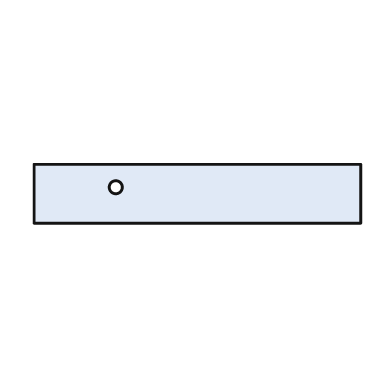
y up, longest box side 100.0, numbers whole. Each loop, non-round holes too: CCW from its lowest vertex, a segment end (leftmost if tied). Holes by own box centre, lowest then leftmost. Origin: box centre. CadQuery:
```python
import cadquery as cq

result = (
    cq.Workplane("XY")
    .moveTo(-50.0, -9.0)
    .lineTo(50.0, -9.0)
    .lineTo(50.0, 9.0)
    .lineTo(-50.0, 9.0)
    .close()
    .moveTo(-25.0, 2.0)
    .circle(2.0)
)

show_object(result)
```